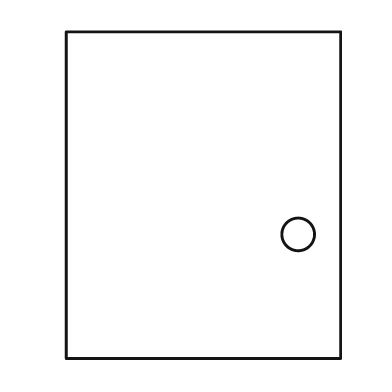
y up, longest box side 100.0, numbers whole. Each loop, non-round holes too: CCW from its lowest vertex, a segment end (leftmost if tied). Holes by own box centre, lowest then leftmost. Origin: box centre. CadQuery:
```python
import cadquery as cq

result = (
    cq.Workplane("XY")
    .moveTo(-42.0, -50.0)
    .lineTo(42.0, -50.0)
    .lineTo(42.0, 50.0)
    .lineTo(-42.0, 50.0)
    .close()
    .moveTo(29.0, -12.0)
    .circle(5.0)
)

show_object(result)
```